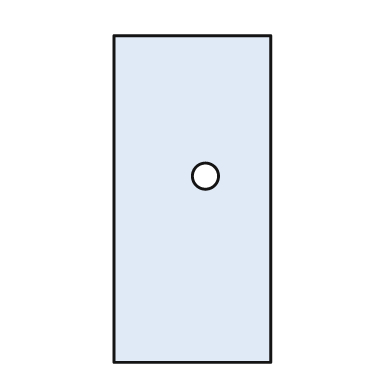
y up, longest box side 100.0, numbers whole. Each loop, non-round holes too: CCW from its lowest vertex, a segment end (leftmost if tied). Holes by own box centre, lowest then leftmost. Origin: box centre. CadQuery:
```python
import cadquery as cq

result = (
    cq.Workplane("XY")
    .moveTo(-24.0, -50.0)
    .lineTo(24.0, -50.0)
    .lineTo(24.0, 50.0)
    .lineTo(-24.0, 50.0)
    .close()
    .moveTo(4.0, 7.0)
    .circle(4.0)
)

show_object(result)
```